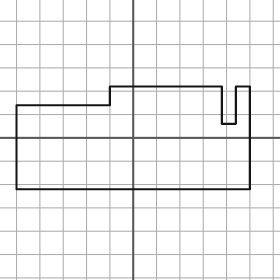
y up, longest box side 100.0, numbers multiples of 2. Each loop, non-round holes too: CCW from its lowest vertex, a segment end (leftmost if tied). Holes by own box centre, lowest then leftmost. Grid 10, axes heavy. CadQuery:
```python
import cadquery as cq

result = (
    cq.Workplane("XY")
    .moveTo(-50.0, -22.0)
    .lineTo(50.0, -22.0)
    .lineTo(50.0, 22.0)
    .lineTo(44.0, 22.0)
    .lineTo(44.0, 6.0)
    .lineTo(38.0, 6.0)
    .lineTo(38.0, 22.0)
    .lineTo(-10.0, 22.0)
    .lineTo(-10.0, 14.0)
    .lineTo(-50.0, 14.0)
    .close()
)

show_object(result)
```